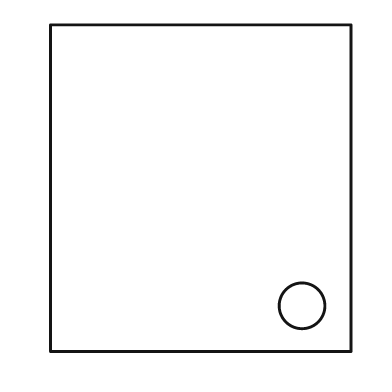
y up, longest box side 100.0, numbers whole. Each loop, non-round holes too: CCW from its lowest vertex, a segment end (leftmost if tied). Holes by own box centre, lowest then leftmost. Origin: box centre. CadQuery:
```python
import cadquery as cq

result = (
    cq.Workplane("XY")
    .moveTo(-46.0, -50.0)
    .lineTo(46.0, -50.0)
    .lineTo(46.0, 50.0)
    .lineTo(-46.0, 50.0)
    .close()
    .moveTo(31.0, -36.0)
    .circle(7.0)
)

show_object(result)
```